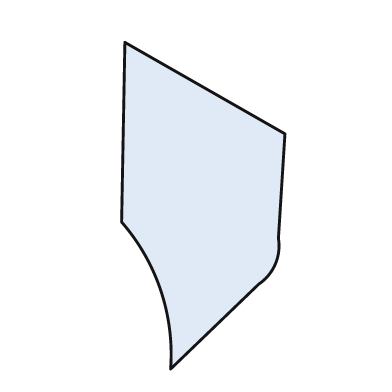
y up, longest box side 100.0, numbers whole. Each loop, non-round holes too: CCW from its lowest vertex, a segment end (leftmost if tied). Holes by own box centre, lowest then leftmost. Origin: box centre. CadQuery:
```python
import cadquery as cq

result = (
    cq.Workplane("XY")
    .moveTo(-10.0, -50.0)
    .lineTo(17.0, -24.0)
    .threePointArc((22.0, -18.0), (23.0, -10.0))
    .lineTo(25.0, 22.0)
    .lineTo(-24.0, 50.0)
    .lineTo(-25.0, -5.0)
    .threePointArc((-13.0, -26.0), (-10.0, -50.0))
    .close()
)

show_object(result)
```